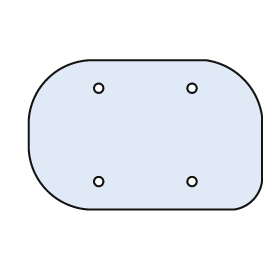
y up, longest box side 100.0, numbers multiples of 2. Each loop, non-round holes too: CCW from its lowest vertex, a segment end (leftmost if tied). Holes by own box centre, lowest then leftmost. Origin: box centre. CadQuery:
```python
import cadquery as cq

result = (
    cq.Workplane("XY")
    .moveTo(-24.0, -32.0)
    .lineTo(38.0, -32.0)
    .threePointArc((46.0, -28.0), (50.0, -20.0))
    .lineTo(50.0, 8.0)
    .threePointArc((42.0, 24.0), (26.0, 32.0))
    .lineTo(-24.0, 32.0)
    .threePointArc((-42.0, 24.0), (-50.0, 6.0))
    .lineTo(-50.0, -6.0)
    .threePointArc((-42.0, -24.0), (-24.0, -32.0))
    .close()
    .moveTo(-20.0, -20.0)
    .circle(2.0)
    .moveTo(20.0, -20.0)
    .circle(2.0)
    .moveTo(-20.0, 20.0)
    .circle(2.0)
    .moveTo(20.0, 20.0)
    .circle(2.0)
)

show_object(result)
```